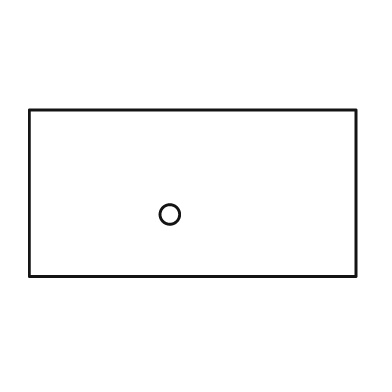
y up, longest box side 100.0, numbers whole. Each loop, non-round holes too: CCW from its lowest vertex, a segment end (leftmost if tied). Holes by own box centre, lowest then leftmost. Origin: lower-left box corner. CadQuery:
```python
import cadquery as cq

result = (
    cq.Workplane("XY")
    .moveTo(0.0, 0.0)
    .lineTo(100.0, 0.0)
    .lineTo(100.0, 51.0)
    .lineTo(0.0, 51.0)
    .close()
    .moveTo(43.0, 19.0)
    .circle(3.0)
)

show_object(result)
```